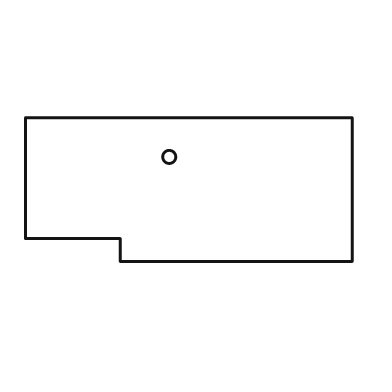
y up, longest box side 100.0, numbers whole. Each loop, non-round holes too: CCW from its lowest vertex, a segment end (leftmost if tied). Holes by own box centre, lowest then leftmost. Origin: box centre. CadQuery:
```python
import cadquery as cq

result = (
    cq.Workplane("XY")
    .moveTo(-21.0, -22.0)
    .lineTo(50.0, -22.0)
    .lineTo(50.0, 22.0)
    .lineTo(-50.0, 22.0)
    .lineTo(-50.0, -15.0)
    .lineTo(-21.0, -15.0)
    .close()
    .moveTo(-6.0, 10.0)
    .circle(2.0)
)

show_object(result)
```